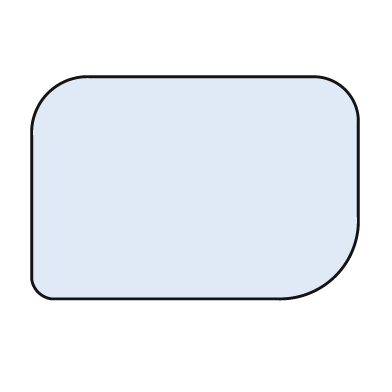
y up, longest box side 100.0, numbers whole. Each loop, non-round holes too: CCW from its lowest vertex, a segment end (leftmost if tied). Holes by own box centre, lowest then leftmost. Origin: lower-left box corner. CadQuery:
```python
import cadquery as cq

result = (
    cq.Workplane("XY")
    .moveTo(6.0, 0.0)
    .lineTo(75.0, 0.0)
    .threePointArc((93.0, 7.0), (100.0, 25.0))
    .lineTo(100.0, 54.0)
    .threePointArc((96.0, 64.0), (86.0, 68.0))
    .lineTo(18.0, 68.0)
    .threePointArc((5.0, 63.0), (0.0, 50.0))
    .lineTo(0.0, 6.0)
    .threePointArc((2.0, 2.0), (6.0, 0.0))
    .close()
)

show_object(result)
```